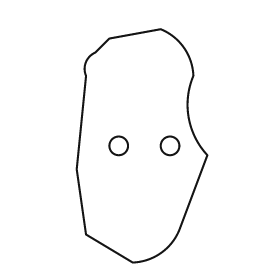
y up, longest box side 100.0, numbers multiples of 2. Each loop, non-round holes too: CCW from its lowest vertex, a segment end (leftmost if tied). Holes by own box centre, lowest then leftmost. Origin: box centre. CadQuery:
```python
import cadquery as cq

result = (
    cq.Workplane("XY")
    .moveTo(-4.0, -50.0)
    .threePointArc((8.0, -46.0), (16.0, -36.0))
    .lineTo(28.0, -4.0)
    .threePointArc((20.0, 12.0), (22.0, 30.0))
    .threePointArc((18.0, 42.0), (8.0, 50.0))
    .lineTo(-14.0, 46.0)
    .lineTo(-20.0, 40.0)
    .threePointArc((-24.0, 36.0), (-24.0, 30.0))
    .lineTo(-28.0, -10.0)
    .lineTo(-24.0, -38.0)
    .close()
    .moveTo(-10.0, 0.0)
    .circle(4.0)
    .moveTo(12.0, 0.0)
    .circle(4.0)
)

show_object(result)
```